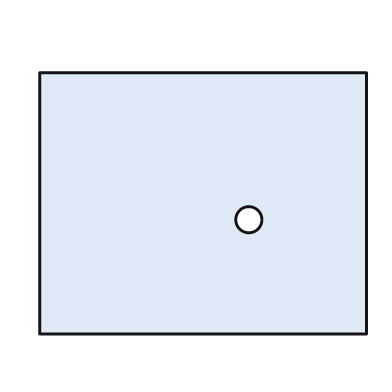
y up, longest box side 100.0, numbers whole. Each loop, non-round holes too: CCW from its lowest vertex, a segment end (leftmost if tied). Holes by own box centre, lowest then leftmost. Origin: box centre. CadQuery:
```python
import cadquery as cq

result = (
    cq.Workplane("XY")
    .moveTo(-50.0, -40.0)
    .lineTo(50.0, -40.0)
    .lineTo(50.0, 40.0)
    .lineTo(-50.0, 40.0)
    .close()
    .moveTo(14.0, -5.0)
    .circle(4.0)
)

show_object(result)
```